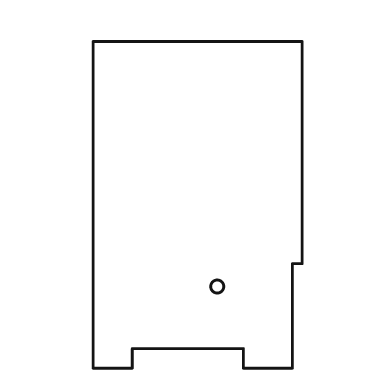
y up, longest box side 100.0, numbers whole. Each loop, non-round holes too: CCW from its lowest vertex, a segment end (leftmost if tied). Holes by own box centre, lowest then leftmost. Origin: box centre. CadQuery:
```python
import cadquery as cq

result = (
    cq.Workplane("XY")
    .moveTo(-32.0, -50.0)
    .lineTo(-20.0, -50.0)
    .lineTo(-20.0, -44.0)
    .lineTo(14.0, -44.0)
    .lineTo(14.0, -50.0)
    .lineTo(29.0, -50.0)
    .lineTo(29.0, -18.0)
    .lineTo(32.0, -18.0)
    .lineTo(32.0, 50.0)
    .lineTo(-32.0, 50.0)
    .close()
    .moveTo(6.0, -25.0)
    .circle(2.0)
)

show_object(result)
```